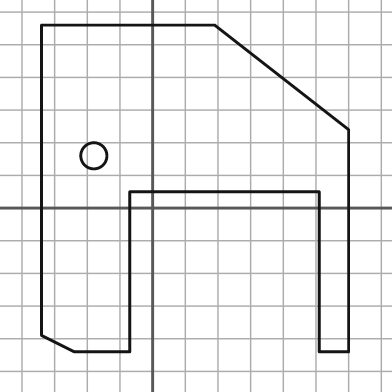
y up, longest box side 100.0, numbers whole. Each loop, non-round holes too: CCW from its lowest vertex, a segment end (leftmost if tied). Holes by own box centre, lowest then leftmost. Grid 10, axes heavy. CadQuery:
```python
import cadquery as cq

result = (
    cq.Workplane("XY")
    .moveTo(-24.0, -44.0)
    .lineTo(-7.0, -44.0)
    .lineTo(-7.0, 5.0)
    .lineTo(51.0, 5.0)
    .lineTo(51.0, -44.0)
    .lineTo(60.0, -44.0)
    .lineTo(60.0, 24.0)
    .lineTo(19.0, 56.0)
    .lineTo(-34.0, 56.0)
    .lineTo(-34.0, -39.0)
    .close()
    .moveTo(-18.0, 16.0)
    .circle(4.0)
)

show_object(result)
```